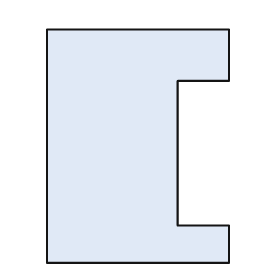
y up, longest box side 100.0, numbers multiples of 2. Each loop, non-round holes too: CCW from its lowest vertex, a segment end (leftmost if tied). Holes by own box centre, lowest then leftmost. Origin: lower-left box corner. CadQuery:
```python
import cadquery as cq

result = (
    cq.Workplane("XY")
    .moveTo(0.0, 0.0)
    .lineTo(78.0, 0.0)
    .lineTo(78.0, 16.0)
    .lineTo(56.0, 16.0)
    .lineTo(56.0, 78.0)
    .lineTo(78.0, 78.0)
    .lineTo(78.0, 100.0)
    .lineTo(0.0, 100.0)
    .close()
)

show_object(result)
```